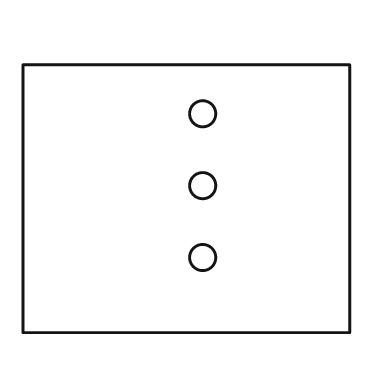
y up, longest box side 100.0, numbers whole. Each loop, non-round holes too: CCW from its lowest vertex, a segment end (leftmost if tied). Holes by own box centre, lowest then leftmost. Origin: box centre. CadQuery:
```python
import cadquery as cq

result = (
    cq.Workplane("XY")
    .moveTo(-50.0, -41.0)
    .lineTo(50.0, -41.0)
    .lineTo(50.0, 41.0)
    .lineTo(-50.0, 41.0)
    .close()
    .moveTo(5.0, -18.0)
    .circle(4.0)
    .moveTo(5.0, 4.0)
    .circle(4.0)
    .moveTo(5.0, 26.0)
    .circle(4.0)
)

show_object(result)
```